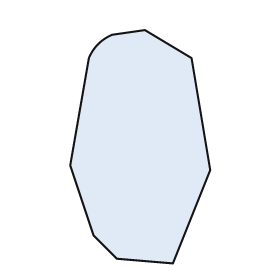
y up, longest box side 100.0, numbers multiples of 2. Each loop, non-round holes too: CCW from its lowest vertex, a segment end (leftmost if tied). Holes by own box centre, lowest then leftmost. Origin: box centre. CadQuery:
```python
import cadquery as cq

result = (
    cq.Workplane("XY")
    .moveTo(14.0, -50.0)
    .lineTo(30.0, -10.0)
    .lineTo(22.0, 38.0)
    .lineTo(2.0, 50.0)
    .lineTo(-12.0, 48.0)
    .threePointArc((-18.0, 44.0), (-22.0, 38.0))
    .lineTo(-30.0, -8.0)
    .lineTo(-20.0, -38.0)
    .lineTo(-10.0, -48.0)
    .close()
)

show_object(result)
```